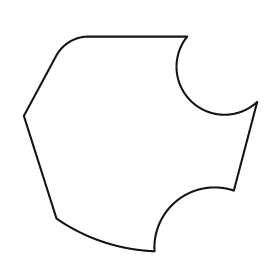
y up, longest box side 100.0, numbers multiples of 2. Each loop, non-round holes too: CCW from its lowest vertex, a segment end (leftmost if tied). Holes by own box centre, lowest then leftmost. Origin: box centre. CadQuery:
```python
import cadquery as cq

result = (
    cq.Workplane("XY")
    .moveTo(6.0, -46.0)
    .threePointArc((16.0, -24.0), (40.0, -20.0))
    .lineTo(50.0, 18.0)
    .threePointArc((22.0, 18.0), (20.0, 46.0))
    .lineTo(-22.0, 46.0)
    .threePointArc((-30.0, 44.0), (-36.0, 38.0))
    .lineTo(-50.0, 12.0)
    .lineTo(-36.0, -32.0)
    .threePointArc((-16.0, -42.0), (6.0, -46.0))
    .close()
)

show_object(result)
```